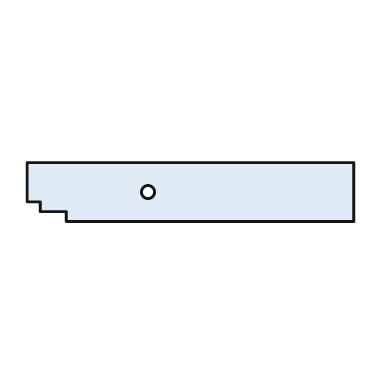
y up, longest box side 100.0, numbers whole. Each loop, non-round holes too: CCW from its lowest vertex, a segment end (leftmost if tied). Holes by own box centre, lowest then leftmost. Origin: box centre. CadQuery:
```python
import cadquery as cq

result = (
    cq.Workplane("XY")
    .moveTo(-38.0, -9.0)
    .lineTo(50.0, -9.0)
    .lineTo(50.0, 9.0)
    .lineTo(-50.0, 9.0)
    .lineTo(-50.0, -3.0)
    .lineTo(-46.0, -3.0)
    .lineTo(-46.0, -6.0)
    .lineTo(-38.0, -6.0)
    .close()
    .moveTo(-13.0, 0.0)
    .circle(2.0)
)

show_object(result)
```